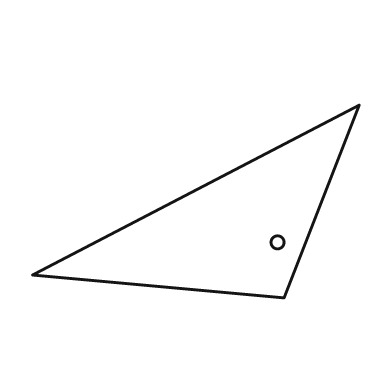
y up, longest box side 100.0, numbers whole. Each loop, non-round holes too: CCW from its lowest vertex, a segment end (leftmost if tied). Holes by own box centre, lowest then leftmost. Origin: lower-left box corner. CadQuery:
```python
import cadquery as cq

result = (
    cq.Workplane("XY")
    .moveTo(77.0, 0.0)
    .lineTo(100.0, 59.0)
    .lineTo(0.0, 7.0)
    .close()
    .moveTo(75.0, 17.0)
    .circle(2.0)
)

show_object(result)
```